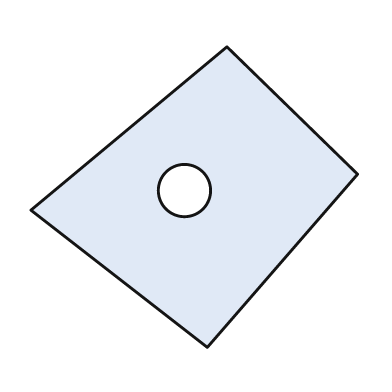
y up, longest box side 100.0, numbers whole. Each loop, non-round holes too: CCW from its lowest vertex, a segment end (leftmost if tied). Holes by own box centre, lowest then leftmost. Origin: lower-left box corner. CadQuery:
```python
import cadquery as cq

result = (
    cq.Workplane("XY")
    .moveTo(54.0, 0.0)
    .lineTo(100.0, 53.0)
    .lineTo(60.0, 92.0)
    .lineTo(0.0, 42.0)
    .close()
    .moveTo(47.0, 48.0)
    .circle(8.0)
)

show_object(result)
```